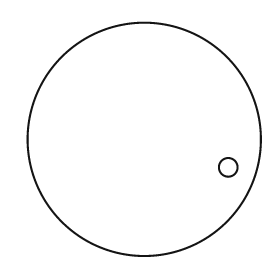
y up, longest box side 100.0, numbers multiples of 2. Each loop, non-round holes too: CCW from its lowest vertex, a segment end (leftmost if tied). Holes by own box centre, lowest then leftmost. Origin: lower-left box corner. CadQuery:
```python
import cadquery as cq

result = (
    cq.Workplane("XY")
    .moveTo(50.0, 50.0)
    .circle(50.0)
    .moveTo(86.0, 38.0)
    .circle(4.0)
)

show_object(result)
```